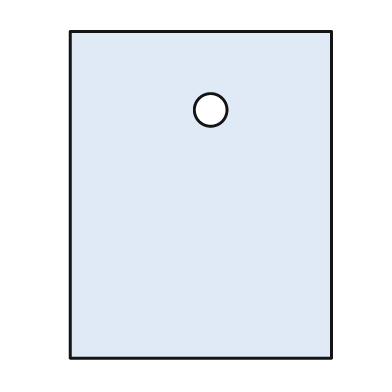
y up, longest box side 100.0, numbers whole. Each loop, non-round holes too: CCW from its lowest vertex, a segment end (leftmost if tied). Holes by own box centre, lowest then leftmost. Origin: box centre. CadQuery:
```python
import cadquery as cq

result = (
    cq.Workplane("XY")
    .moveTo(-40.0, -50.0)
    .lineTo(40.0, -50.0)
    .lineTo(40.0, 50.0)
    .lineTo(-40.0, 50.0)
    .close()
    .moveTo(3.0, 26.0)
    .circle(5.0)
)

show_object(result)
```